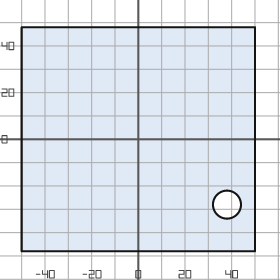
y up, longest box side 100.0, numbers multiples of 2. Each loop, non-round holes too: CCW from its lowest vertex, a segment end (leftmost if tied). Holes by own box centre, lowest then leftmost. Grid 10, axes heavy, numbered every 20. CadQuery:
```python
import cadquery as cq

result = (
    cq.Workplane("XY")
    .moveTo(-50.0, -48.0)
    .lineTo(50.0, -48.0)
    .lineTo(50.0, 48.0)
    .lineTo(-50.0, 48.0)
    .close()
    .moveTo(38.0, -28.0)
    .circle(6.0)
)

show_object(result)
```